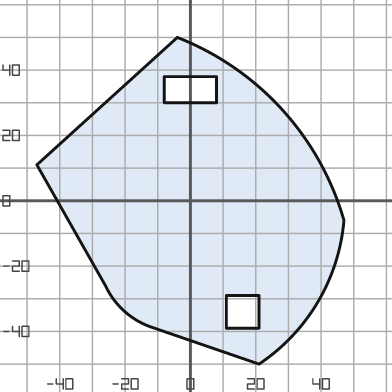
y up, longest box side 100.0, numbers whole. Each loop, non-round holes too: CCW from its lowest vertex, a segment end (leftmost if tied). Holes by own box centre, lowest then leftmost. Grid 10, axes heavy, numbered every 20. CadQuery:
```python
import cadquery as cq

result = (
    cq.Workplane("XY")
    .moveTo(21.0, -50.0)
    .threePointArc((39.0, -31.0), (47.0, -6.0))
    .threePointArc((28.0, 28.0), (-4.0, 50.0))
    .lineTo(-47.0, 11.0)
    .lineTo(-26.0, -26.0)
    .threePointArc((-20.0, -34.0), (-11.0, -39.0))
    .close()
    .moveTo(11.0, -39.0)
    .lineTo(21.0, -39.0)
    .lineTo(21.0, -29.0)
    .lineTo(11.0, -29.0)
    .close()
    .moveTo(-8.0, 30.0)
    .lineTo(8.0, 30.0)
    .lineTo(8.0, 38.0)
    .lineTo(-8.0, 38.0)
    .close()
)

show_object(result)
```